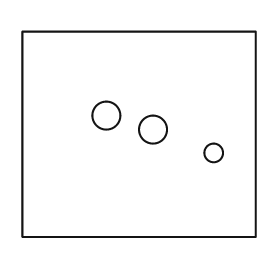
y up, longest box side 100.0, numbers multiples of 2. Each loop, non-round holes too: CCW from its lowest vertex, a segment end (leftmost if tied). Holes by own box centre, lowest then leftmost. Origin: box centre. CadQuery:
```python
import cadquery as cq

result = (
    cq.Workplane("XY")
    .moveTo(-50.0, -44.0)
    .lineTo(50.0, -44.0)
    .lineTo(50.0, 44.0)
    .lineTo(-50.0, 44.0)
    .close()
    .moveTo(32.0, -8.0)
    .circle(4.0)
    .moveTo(6.0, 2.0)
    .circle(6.0)
    .moveTo(-14.0, 8.0)
    .circle(6.0)
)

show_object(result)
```